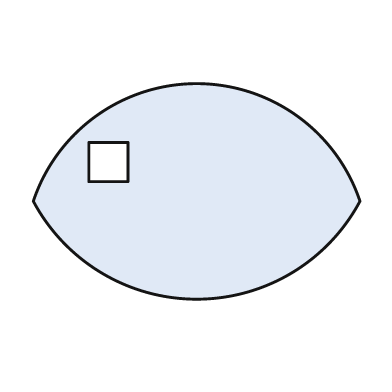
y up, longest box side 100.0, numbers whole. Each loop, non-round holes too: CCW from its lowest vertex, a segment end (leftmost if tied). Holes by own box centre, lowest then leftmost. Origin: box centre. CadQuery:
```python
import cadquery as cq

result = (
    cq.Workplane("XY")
    .moveTo(-50.0, -3.0)
    .threePointArc((0.0, -33.0), (50.0, -3.0))
    .threePointArc((0.0, 33.0), (-50.0, -3.0))
    .close()
    .moveTo(-33.0, 3.0)
    .lineTo(-21.0, 3.0)
    .lineTo(-21.0, 15.0)
    .lineTo(-33.0, 15.0)
    .close()
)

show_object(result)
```